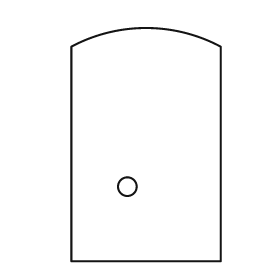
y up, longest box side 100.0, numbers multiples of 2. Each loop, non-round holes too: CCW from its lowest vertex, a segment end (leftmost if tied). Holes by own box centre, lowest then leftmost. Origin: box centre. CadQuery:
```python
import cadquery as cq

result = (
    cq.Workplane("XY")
    .moveTo(-32.0, -50.0)
    .lineTo(32.0, -50.0)
    .lineTo(32.0, 42.0)
    .threePointArc((0.0, 50.0), (-32.0, 42.0))
    .close()
    .moveTo(-8.0, -18.0)
    .circle(4.0)
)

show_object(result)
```